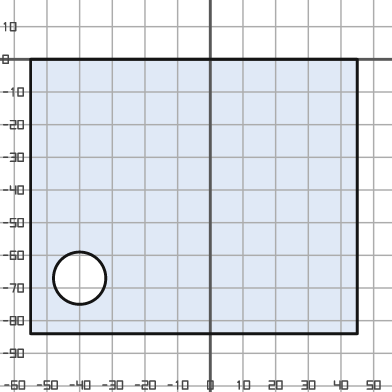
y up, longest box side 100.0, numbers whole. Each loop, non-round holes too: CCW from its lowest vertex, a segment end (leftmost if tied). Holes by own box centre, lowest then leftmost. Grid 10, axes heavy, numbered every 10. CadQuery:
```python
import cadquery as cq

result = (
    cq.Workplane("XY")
    .moveTo(-55.0, -84.0)
    .lineTo(45.0, -84.0)
    .lineTo(45.0, 0.0)
    .lineTo(-55.0, 0.0)
    .close()
    .moveTo(-40.0, -67.0)
    .circle(8.0)
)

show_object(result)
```